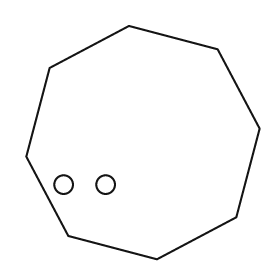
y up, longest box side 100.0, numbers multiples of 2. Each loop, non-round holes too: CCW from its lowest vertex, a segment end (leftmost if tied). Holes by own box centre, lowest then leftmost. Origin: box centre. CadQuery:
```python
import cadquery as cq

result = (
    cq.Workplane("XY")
    .moveTo(6.0, -50.0)
    .lineTo(40.0, -32.0)
    .lineTo(50.0, 6.0)
    .lineTo(32.0, 40.0)
    .lineTo(-6.0, 50.0)
    .lineTo(-40.0, 32.0)
    .lineTo(-50.0, -6.0)
    .lineTo(-32.0, -40.0)
    .close()
    .moveTo(-34.0, -18.0)
    .circle(4.0)
    .moveTo(-16.0, -18.0)
    .circle(4.0)
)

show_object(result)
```